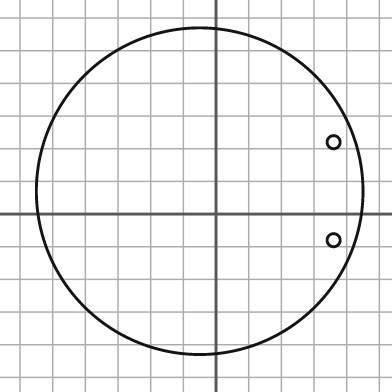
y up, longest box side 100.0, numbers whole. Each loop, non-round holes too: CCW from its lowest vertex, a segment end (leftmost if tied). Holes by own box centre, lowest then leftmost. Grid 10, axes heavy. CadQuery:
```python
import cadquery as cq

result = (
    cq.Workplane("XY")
    .moveTo(-5.0, 7.0)
    .circle(50.0)
    .moveTo(36.0, -8.0)
    .circle(2.0)
    .moveTo(36.0, 22.0)
    .circle(2.0)
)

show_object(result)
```